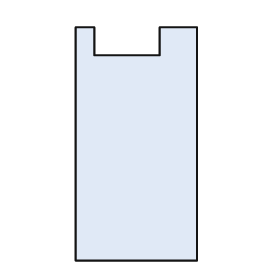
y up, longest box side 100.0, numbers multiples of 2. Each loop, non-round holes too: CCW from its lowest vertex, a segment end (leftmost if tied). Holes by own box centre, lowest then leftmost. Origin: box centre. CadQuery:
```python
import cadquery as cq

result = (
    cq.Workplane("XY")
    .moveTo(-26.0, -50.0)
    .lineTo(26.0, -50.0)
    .lineTo(26.0, 50.0)
    .lineTo(10.0, 50.0)
    .lineTo(10.0, 38.0)
    .lineTo(-18.0, 38.0)
    .lineTo(-18.0, 50.0)
    .lineTo(-26.0, 50.0)
    .close()
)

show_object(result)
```